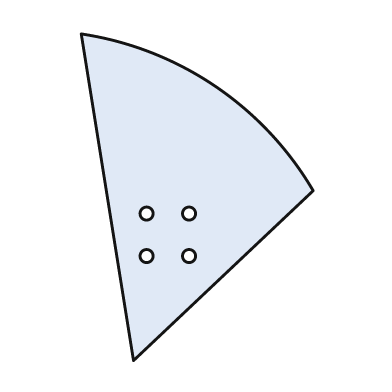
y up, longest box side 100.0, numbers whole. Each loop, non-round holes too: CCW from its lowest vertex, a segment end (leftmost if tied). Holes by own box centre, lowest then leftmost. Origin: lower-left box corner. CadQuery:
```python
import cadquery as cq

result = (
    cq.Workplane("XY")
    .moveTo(16.0, 0.0)
    .lineTo(71.0, 52.0)
    .threePointArc((41.0, 84.0), (0.0, 100.0))
    .close()
    .moveTo(20.0, 32.0)
    .circle(2.0)
    .moveTo(33.0, 32.0)
    .circle(2.0)
    .moveTo(20.0, 45.0)
    .circle(2.0)
    .moveTo(33.0, 45.0)
    .circle(2.0)
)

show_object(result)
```